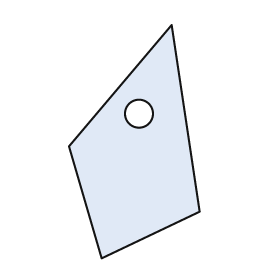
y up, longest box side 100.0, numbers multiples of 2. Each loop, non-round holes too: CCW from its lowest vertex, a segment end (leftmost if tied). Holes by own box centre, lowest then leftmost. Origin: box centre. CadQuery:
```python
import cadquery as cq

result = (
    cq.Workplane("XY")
    .moveTo(-14.0, -50.0)
    .lineTo(28.0, -30.0)
    .lineTo(16.0, 50.0)
    .lineTo(-28.0, -2.0)
    .close()
    .moveTo(2.0, 12.0)
    .circle(6.0)
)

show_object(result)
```